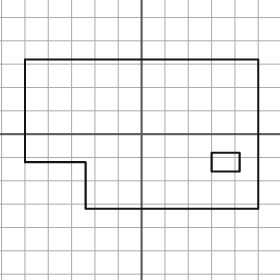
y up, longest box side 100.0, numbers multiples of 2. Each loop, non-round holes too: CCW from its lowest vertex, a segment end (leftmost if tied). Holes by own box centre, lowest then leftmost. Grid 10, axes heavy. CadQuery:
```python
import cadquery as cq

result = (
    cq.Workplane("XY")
    .moveTo(-24.0, -32.0)
    .lineTo(50.0, -32.0)
    .lineTo(50.0, 32.0)
    .lineTo(-50.0, 32.0)
    .lineTo(-50.0, -12.0)
    .lineTo(-24.0, -12.0)
    .close()
    .moveTo(30.0, -16.0)
    .lineTo(42.0, -16.0)
    .lineTo(42.0, -8.0)
    .lineTo(30.0, -8.0)
    .close()
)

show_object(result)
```